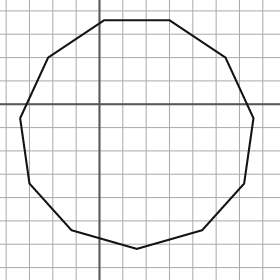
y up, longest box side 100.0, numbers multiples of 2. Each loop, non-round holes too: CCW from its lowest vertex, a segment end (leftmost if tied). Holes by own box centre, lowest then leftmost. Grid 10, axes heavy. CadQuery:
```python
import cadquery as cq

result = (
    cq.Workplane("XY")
    .moveTo(16.0, -62.0)
    .lineTo(44.0, -54.0)
    .lineTo(62.0, -34.0)
    .lineTo(66.0, -6.0)
    .lineTo(54.0, 20.0)
    .lineTo(30.0, 36.0)
    .lineTo(2.0, 36.0)
    .lineTo(-22.0, 20.0)
    .lineTo(-34.0, -6.0)
    .lineTo(-30.0, -34.0)
    .lineTo(-12.0, -54.0)
    .close()
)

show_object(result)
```